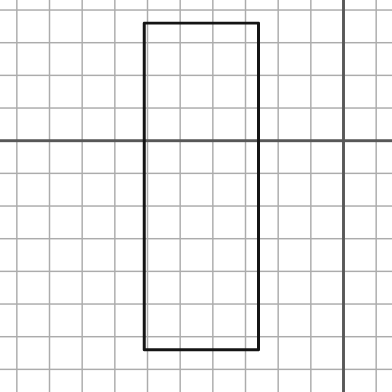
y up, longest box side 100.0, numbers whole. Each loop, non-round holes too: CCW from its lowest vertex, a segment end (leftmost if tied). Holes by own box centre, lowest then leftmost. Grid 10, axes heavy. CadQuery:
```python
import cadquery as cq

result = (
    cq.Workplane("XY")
    .moveTo(-61.0, -64.0)
    .lineTo(-26.0, -64.0)
    .lineTo(-26.0, 36.0)
    .lineTo(-61.0, 36.0)
    .close()
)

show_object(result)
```